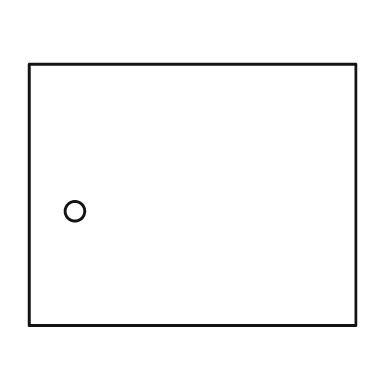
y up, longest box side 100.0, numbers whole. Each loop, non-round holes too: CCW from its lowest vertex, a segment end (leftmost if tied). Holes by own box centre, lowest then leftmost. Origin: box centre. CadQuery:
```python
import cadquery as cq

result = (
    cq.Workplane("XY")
    .moveTo(-50.0, -40.0)
    .lineTo(50.0, -40.0)
    .lineTo(50.0, 40.0)
    .lineTo(-50.0, 40.0)
    .close()
    .moveTo(-36.0, -5.0)
    .circle(3.0)
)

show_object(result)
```